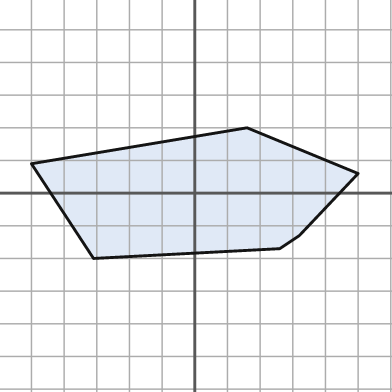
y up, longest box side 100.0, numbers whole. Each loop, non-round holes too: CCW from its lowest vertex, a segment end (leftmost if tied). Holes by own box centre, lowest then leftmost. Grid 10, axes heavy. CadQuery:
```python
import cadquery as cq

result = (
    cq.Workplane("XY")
    .moveTo(-31.0, -20.0)
    .lineTo(26.0, -17.0)
    .lineTo(32.0, -13.0)
    .lineTo(50.0, 6.0)
    .lineTo(16.0, 20.0)
    .lineTo(-50.0, 9.0)
    .close()
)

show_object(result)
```